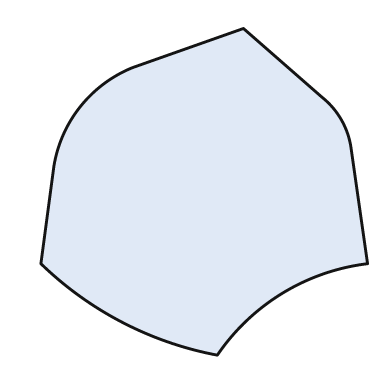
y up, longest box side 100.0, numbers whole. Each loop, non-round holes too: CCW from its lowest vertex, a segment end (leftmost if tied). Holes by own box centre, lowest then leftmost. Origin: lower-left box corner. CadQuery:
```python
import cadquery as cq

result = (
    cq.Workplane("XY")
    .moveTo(54.0, 0.0)
    .threePointArc((74.0, 19.0), (100.0, 28.0))
    .lineTo(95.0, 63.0)
    .threePointArc((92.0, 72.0), (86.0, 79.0))
    .lineTo(62.0, 100.0)
    .lineTo(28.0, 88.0)
    .threePointArc((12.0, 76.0), (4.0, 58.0))
    .lineTo(0.0, 28.0)
    .threePointArc((25.0, 10.0), (54.0, 0.0))
    .close()
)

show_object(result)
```